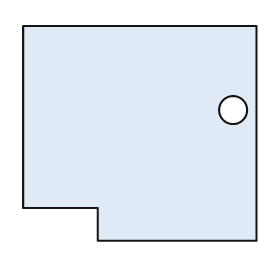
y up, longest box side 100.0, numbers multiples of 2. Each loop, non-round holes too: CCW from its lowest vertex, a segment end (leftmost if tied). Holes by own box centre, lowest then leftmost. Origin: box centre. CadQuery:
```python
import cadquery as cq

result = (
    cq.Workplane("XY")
    .moveTo(-18.0, -46.0)
    .lineTo(50.0, -46.0)
    .lineTo(50.0, 46.0)
    .lineTo(-50.0, 46.0)
    .lineTo(-50.0, -32.0)
    .lineTo(-18.0, -32.0)
    .close()
    .moveTo(40.0, 10.0)
    .circle(6.0)
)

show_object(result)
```